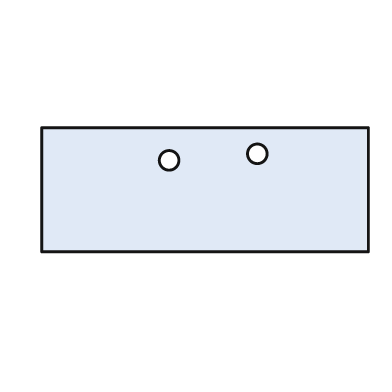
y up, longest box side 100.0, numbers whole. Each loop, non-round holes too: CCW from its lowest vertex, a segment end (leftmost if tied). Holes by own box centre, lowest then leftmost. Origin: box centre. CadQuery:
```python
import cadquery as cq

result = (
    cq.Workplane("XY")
    .moveTo(-50.0, -19.0)
    .lineTo(50.0, -19.0)
    .lineTo(50.0, 19.0)
    .lineTo(-50.0, 19.0)
    .close()
    .moveTo(-11.0, 9.0)
    .circle(3.0)
    .moveTo(16.0, 11.0)
    .circle(3.0)
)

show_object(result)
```